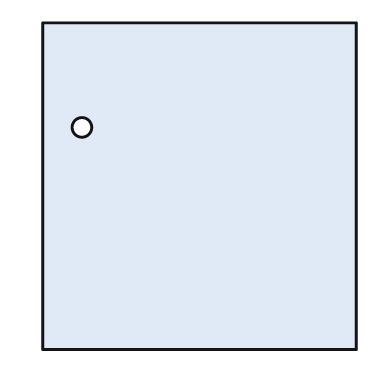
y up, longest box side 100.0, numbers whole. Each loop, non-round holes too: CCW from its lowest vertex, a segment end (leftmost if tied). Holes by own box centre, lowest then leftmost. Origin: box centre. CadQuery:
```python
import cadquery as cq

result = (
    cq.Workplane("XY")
    .moveTo(-48.0, -50.0)
    .lineTo(48.0, -50.0)
    .lineTo(48.0, 50.0)
    .lineTo(-48.0, 50.0)
    .close()
    .moveTo(-36.0, 18.0)
    .circle(3.0)
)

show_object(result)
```